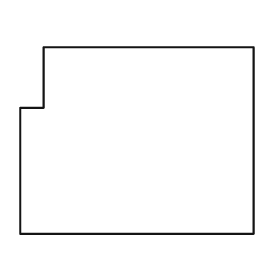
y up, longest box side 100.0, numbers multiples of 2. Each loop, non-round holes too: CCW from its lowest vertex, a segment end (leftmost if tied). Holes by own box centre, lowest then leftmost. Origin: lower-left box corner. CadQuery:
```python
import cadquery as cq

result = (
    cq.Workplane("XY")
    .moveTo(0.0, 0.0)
    .lineTo(100.0, 0.0)
    .lineTo(100.0, 80.0)
    .lineTo(10.0, 80.0)
    .lineTo(10.0, 54.0)
    .lineTo(0.0, 54.0)
    .close()
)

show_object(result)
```